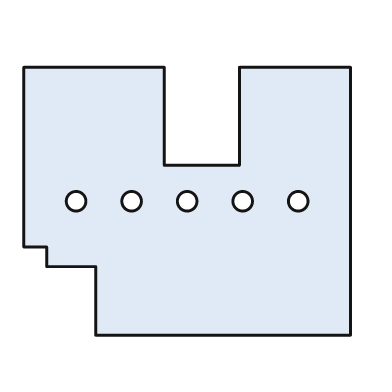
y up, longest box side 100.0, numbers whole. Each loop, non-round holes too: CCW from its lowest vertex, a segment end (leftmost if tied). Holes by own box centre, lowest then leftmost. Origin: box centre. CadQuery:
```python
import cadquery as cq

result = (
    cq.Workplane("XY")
    .moveTo(-28.0, -41.0)
    .lineTo(50.0, -41.0)
    .lineTo(50.0, 41.0)
    .lineTo(16.0, 41.0)
    .lineTo(16.0, 11.0)
    .lineTo(-7.0, 11.0)
    .lineTo(-7.0, 41.0)
    .lineTo(-50.0, 41.0)
    .lineTo(-50.0, -14.0)
    .lineTo(-43.0, -14.0)
    .lineTo(-43.0, -20.0)
    .lineTo(-28.0, -20.0)
    .close()
    .moveTo(-34.0, 0.0)
    .circle(3.0)
    .moveTo(-17.0, 0.0)
    .circle(3.0)
    .moveTo(0.0, 0.0)
    .circle(3.0)
    .moveTo(17.0, 0.0)
    .circle(3.0)
    .moveTo(34.0, 0.0)
    .circle(3.0)
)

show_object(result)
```